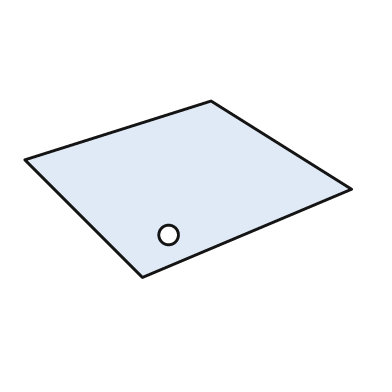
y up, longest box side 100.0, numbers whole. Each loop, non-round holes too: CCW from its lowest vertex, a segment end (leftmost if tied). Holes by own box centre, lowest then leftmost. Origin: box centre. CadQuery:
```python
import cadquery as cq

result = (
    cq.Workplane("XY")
    .moveTo(-14.0, -27.0)
    .lineTo(50.0, 0.0)
    .lineTo(7.0, 27.0)
    .lineTo(-50.0, 9.0)
    .close()
    .moveTo(-6.0, -14.0)
    .circle(3.0)
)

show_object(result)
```